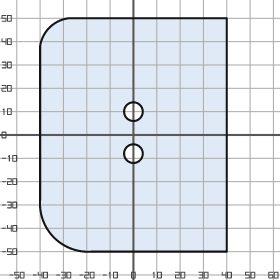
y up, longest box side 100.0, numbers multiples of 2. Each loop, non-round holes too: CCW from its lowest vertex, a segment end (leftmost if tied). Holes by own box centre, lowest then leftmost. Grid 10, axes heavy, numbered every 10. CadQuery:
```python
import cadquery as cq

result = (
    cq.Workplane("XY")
    .moveTo(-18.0, -50.0)
    .lineTo(40.0, -50.0)
    .lineTo(40.0, 50.0)
    .lineTo(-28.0, 50.0)
    .threePointArc((-36.0, 46.0), (-40.0, 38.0))
    .lineTo(-40.0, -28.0)
    .threePointArc((-34.0, -44.0), (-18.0, -50.0))
    .close()
    .moveTo(0.0, -8.0)
    .circle(4.0)
    .moveTo(0.0, 10.0)
    .circle(4.0)
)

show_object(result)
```